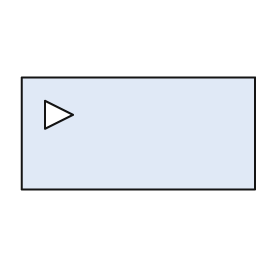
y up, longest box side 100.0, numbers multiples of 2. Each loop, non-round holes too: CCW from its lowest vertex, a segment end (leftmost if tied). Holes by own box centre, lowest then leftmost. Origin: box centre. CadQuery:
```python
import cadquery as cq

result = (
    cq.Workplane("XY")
    .moveTo(-50.0, -24.0)
    .lineTo(50.0, -24.0)
    .lineTo(50.0, 24.0)
    .lineTo(-50.0, 24.0)
    .close()
    .moveTo(-40.0, 2.0)
    .lineTo(-28.0, 8.0)
    .lineTo(-40.0, 14.0)
    .close()
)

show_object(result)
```